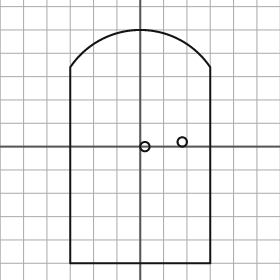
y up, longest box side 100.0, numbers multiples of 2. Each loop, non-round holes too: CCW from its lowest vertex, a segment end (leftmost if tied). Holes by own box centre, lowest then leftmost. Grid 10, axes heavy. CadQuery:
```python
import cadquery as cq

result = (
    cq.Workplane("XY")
    .moveTo(-30.0, -50.0)
    .lineTo(30.0, -50.0)
    .lineTo(30.0, 34.0)
    .threePointArc((0.0, 50.0), (-30.0, 34.0))
    .close()
    .moveTo(2.0, 0.0)
    .circle(2.0)
    .moveTo(18.0, 2.0)
    .circle(2.0)
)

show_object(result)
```